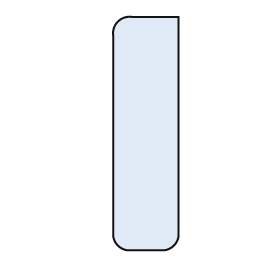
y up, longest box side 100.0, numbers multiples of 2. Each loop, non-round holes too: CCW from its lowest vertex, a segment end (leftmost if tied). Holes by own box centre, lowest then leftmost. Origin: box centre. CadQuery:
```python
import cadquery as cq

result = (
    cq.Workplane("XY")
    .moveTo(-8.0, -50.0)
    .lineTo(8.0, -50.0)
    .threePointArc((12.0, -48.0), (14.0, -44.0))
    .lineTo(14.0, 50.0)
    .lineTo(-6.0, 50.0)
    .threePointArc((-12.0, 48.0), (-14.0, 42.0))
    .lineTo(-14.0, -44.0)
    .threePointArc((-12.0, -48.0), (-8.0, -50.0))
    .close()
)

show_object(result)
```